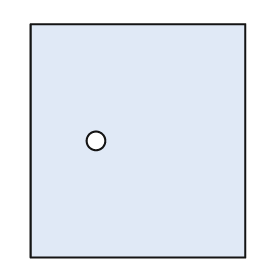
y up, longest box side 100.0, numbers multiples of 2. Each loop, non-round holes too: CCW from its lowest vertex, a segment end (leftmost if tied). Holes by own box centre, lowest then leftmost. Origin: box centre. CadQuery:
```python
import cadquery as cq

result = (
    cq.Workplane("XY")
    .moveTo(-46.0, -50.0)
    .lineTo(46.0, -50.0)
    .lineTo(46.0, 50.0)
    .lineTo(-46.0, 50.0)
    .close()
    .moveTo(-18.0, 0.0)
    .circle(4.0)
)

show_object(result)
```